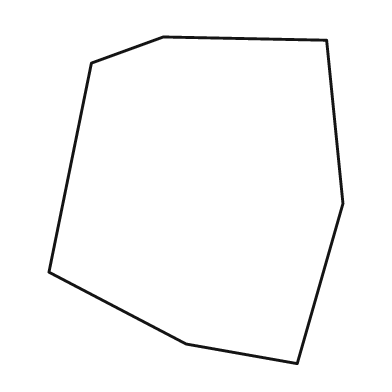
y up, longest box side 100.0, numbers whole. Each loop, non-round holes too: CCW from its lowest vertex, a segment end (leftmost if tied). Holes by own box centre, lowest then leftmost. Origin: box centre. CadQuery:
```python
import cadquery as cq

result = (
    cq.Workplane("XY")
    .moveTo(31.0, -50.0)
    .lineTo(45.0, -1.0)
    .lineTo(40.0, 49.0)
    .lineTo(-10.0, 50.0)
    .lineTo(-32.0, 42.0)
    .lineTo(-45.0, -22.0)
    .lineTo(-3.0, -44.0)
    .close()
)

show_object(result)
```